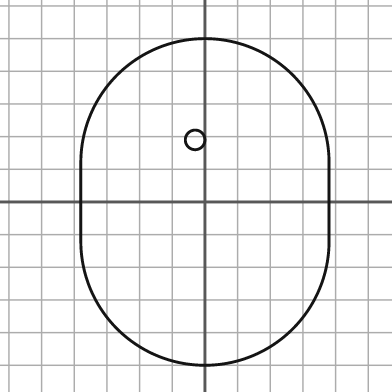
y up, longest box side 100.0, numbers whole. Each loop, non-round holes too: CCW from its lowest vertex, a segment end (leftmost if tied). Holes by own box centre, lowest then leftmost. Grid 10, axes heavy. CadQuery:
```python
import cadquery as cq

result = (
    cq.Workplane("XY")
    .moveTo(-38.0, -12.0)
    .threePointArc((0.0, -50.0), (38.0, -12.0))
    .lineTo(38.0, 12.0)
    .threePointArc((0.0, 50.0), (-38.0, 12.0))
    .close()
    .moveTo(-3.0, 19.0)
    .circle(3.0)
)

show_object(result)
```